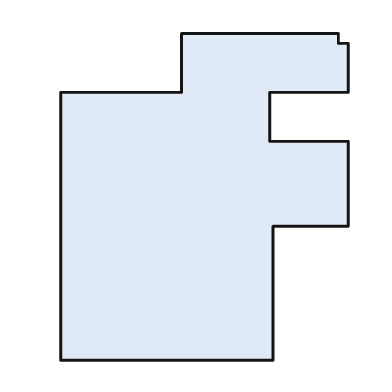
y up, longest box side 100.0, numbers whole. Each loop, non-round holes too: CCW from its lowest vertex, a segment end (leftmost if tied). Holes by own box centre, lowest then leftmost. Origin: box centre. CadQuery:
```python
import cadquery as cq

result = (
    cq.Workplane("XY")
    .moveTo(-44.0, -50.0)
    .lineTo(21.0, -50.0)
    .lineTo(21.0, -9.0)
    .lineTo(44.0, -9.0)
    .lineTo(44.0, 17.0)
    .lineTo(20.0, 17.0)
    .lineTo(20.0, 32.0)
    .lineTo(44.0, 32.0)
    .lineTo(44.0, 47.0)
    .lineTo(41.0, 47.0)
    .lineTo(41.0, 50.0)
    .lineTo(-7.0, 50.0)
    .lineTo(-7.0, 32.0)
    .lineTo(-44.0, 32.0)
    .close()
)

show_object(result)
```